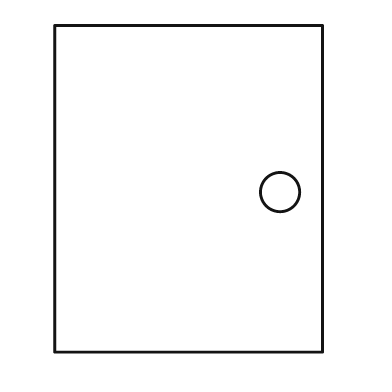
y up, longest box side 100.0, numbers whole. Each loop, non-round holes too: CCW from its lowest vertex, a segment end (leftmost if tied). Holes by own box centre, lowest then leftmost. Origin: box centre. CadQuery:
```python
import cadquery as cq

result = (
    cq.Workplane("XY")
    .moveTo(-41.0, -50.0)
    .lineTo(41.0, -50.0)
    .lineTo(41.0, 50.0)
    .lineTo(-41.0, 50.0)
    .close()
    .moveTo(28.0, -1.0)
    .circle(6.0)
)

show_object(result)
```